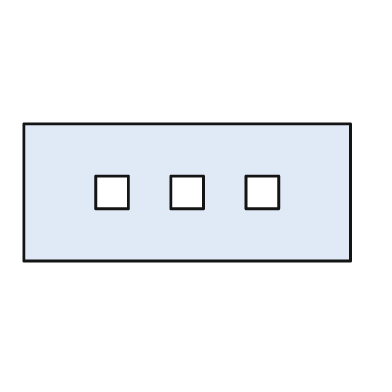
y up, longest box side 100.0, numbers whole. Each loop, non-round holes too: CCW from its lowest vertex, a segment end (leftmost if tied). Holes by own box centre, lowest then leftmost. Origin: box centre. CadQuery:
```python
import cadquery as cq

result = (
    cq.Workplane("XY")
    .moveTo(-50.0, -21.0)
    .lineTo(50.0, -21.0)
    .lineTo(50.0, 21.0)
    .lineTo(-50.0, 21.0)
    .close()
    .moveTo(-28.0, -5.0)
    .lineTo(-18.0, -5.0)
    .lineTo(-18.0, 5.0)
    .lineTo(-28.0, 5.0)
    .close()
    .moveTo(-5.0, -5.0)
    .lineTo(5.0, -5.0)
    .lineTo(5.0, 5.0)
    .lineTo(-5.0, 5.0)
    .close()
    .moveTo(18.0, -5.0)
    .lineTo(28.0, -5.0)
    .lineTo(28.0, 5.0)
    .lineTo(18.0, 5.0)
    .close()
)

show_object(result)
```